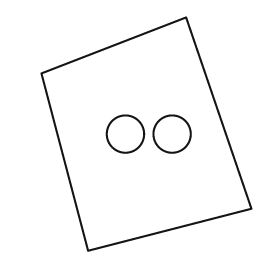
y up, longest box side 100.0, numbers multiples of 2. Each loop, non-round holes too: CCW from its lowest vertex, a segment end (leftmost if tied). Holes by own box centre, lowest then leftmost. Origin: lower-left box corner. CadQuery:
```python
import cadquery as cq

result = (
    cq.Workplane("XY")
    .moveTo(20.0, 0.0)
    .lineTo(90.0, 18.0)
    .lineTo(62.0, 100.0)
    .lineTo(0.0, 76.0)
    .close()
    .moveTo(36.0, 50.0)
    .circle(8.0)
    .moveTo(56.0, 50.0)
    .circle(8.0)
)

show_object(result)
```